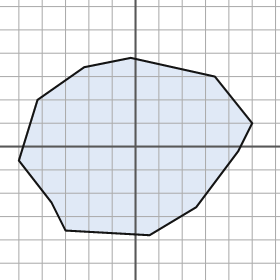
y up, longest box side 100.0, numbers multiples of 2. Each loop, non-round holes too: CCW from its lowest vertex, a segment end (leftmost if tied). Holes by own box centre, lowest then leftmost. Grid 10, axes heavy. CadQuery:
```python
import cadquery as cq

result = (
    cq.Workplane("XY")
    .moveTo(6.0, -38.0)
    .lineTo(26.0, -26.0)
    .lineTo(44.0, -2.0)
    .lineTo(50.0, 10.0)
    .lineTo(34.0, 30.0)
    .lineTo(-2.0, 38.0)
    .lineTo(-22.0, 34.0)
    .lineTo(-42.0, 20.0)
    .lineTo(-50.0, -6.0)
    .lineTo(-36.0, -24.0)
    .lineTo(-30.0, -36.0)
    .close()
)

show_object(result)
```